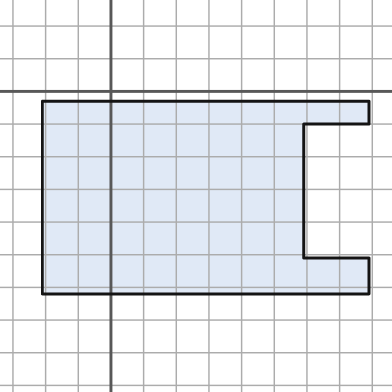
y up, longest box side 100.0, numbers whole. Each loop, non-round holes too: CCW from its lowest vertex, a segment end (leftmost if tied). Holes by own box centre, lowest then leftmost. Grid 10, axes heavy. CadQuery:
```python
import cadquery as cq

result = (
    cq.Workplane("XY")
    .moveTo(-21.0, -62.0)
    .lineTo(79.0, -62.0)
    .lineTo(79.0, -51.0)
    .lineTo(59.0, -51.0)
    .lineTo(59.0, -10.0)
    .lineTo(79.0, -10.0)
    .lineTo(79.0, -3.0)
    .lineTo(-21.0, -3.0)
    .close()
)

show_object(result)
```